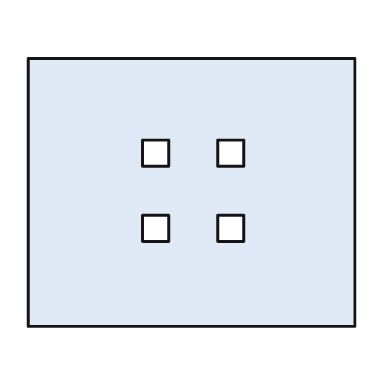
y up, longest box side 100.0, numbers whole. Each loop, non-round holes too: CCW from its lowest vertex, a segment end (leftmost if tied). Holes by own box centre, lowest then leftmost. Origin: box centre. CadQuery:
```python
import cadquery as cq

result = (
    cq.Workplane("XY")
    .moveTo(-50.0, -41.0)
    .lineTo(50.0, -41.0)
    .lineTo(50.0, 41.0)
    .lineTo(-50.0, 41.0)
    .close()
    .moveTo(-15.0, -15.0)
    .lineTo(-7.0, -15.0)
    .lineTo(-7.0, -7.0)
    .lineTo(-15.0, -7.0)
    .close()
    .moveTo(8.0, -15.0)
    .lineTo(16.0, -15.0)
    .lineTo(16.0, -7.0)
    .lineTo(8.0, -7.0)
    .close()
    .moveTo(-15.0, 8.0)
    .lineTo(-7.0, 8.0)
    .lineTo(-7.0, 16.0)
    .lineTo(-15.0, 16.0)
    .close()
    .moveTo(8.0, 8.0)
    .lineTo(16.0, 8.0)
    .lineTo(16.0, 16.0)
    .lineTo(8.0, 16.0)
    .close()
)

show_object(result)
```